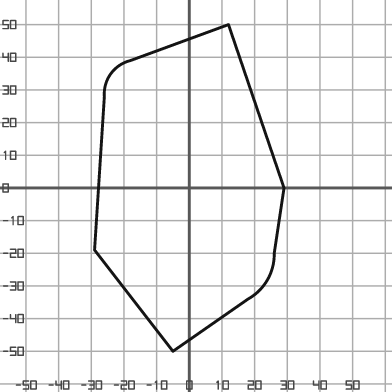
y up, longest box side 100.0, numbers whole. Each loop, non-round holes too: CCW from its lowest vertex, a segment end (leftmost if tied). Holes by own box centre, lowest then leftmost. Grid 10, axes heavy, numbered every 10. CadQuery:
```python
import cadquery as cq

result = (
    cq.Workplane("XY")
    .moveTo(-5.0, -50.0)
    .lineTo(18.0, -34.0)
    .threePointArc((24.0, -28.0), (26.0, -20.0))
    .lineTo(29.0, 0.0)
    .lineTo(12.0, 50.0)
    .lineTo(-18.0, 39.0)
    .threePointArc((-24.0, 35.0), (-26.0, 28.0))
    .lineTo(-29.0, -19.0)
    .close()
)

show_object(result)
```